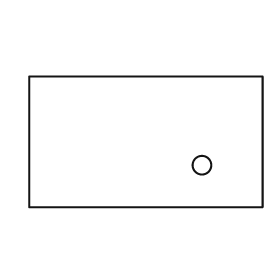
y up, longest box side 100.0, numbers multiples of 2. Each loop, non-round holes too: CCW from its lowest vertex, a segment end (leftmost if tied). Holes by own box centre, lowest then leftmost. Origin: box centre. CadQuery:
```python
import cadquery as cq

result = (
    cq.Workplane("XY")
    .moveTo(-50.0, -28.0)
    .lineTo(50.0, -28.0)
    .lineTo(50.0, 28.0)
    .lineTo(-50.0, 28.0)
    .close()
    .moveTo(24.0, -10.0)
    .circle(4.0)
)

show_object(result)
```